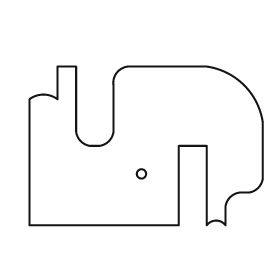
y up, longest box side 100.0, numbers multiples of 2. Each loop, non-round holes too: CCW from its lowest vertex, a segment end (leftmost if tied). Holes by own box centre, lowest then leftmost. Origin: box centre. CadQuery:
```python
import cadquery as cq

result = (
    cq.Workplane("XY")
    .moveTo(-50.0, -34.0)
    .lineTo(14.0, -34.0)
    .lineTo(14.0, 0.0)
    .lineTo(26.0, 0.0)
    .lineTo(26.0, -34.0)
    .threePointArc((30.0, -32.0), (34.0, -34.0))
    .lineTo(34.0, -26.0)
    .threePointArc((36.0, -22.0), (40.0, -20.0))
    .lineTo(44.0, -20.0)
    .threePointArc((48.0, -18.0), (50.0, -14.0))
    .lineTo(50.0, 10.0)
    .threePointArc((42.0, 26.0), (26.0, 34.0))
    .lineTo(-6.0, 34.0)
    .threePointArc((-12.0, 32.0), (-14.0, 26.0))
    .lineTo(-14.0, 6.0)
    .threePointArc((-16.0, 2.0), (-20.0, 0.0))
    .lineTo(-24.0, 0.0)
    .threePointArc((-28.0, 2.0), (-30.0, 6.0))
    .lineTo(-30.0, 34.0)
    .lineTo(-38.0, 34.0)
    .lineTo(-38.0, 20.0)
    .threePointArc((-44.0, 22.0), (-50.0, 20.0))
    .close()
    .moveTo(-2.0, -12.0)
    .circle(2.0)
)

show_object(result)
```